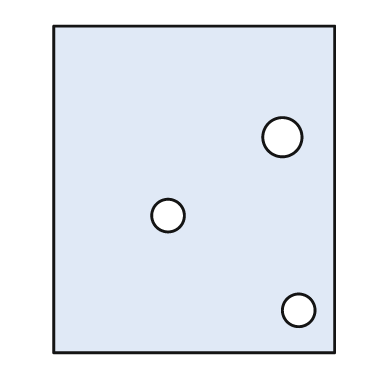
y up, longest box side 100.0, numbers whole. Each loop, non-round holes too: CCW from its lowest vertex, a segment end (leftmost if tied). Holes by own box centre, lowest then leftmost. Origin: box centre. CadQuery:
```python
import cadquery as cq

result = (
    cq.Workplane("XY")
    .moveTo(-43.0, -50.0)
    .lineTo(43.0, -50.0)
    .lineTo(43.0, 50.0)
    .lineTo(-43.0, 50.0)
    .close()
    .moveTo(32.0, -37.0)
    .circle(5.0)
    .moveTo(-8.0, -8.0)
    .circle(5.0)
    .moveTo(27.0, 16.0)
    .circle(6.0)
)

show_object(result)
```